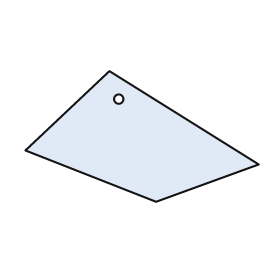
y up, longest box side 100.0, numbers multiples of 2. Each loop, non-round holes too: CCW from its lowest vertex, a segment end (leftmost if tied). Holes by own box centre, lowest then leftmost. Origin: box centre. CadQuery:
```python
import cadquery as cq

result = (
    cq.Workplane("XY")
    .moveTo(6.0, -28.0)
    .lineTo(50.0, -12.0)
    .lineTo(-14.0, 28.0)
    .lineTo(-50.0, -6.0)
    .close()
    .moveTo(-10.0, 16.0)
    .circle(2.0)
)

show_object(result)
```